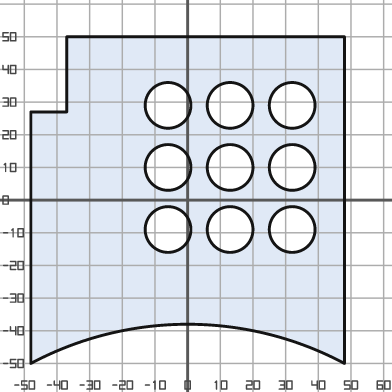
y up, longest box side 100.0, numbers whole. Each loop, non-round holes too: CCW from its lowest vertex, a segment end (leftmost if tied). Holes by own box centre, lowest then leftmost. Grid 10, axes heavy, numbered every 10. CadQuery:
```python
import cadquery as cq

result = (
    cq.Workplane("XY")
    .moveTo(-48.0, -50.0)
    .threePointArc((0.0, -38.0), (48.0, -50.0))
    .lineTo(48.0, 50.0)
    .lineTo(-37.0, 50.0)
    .lineTo(-37.0, 27.0)
    .lineTo(-48.0, 27.0)
    .close()
    .moveTo(-6.0, -9.0)
    .circle(7.0)
    .moveTo(13.0, -9.0)
    .circle(7.0)
    .moveTo(32.0, -9.0)
    .circle(7.0)
    .moveTo(-6.0, 10.0)
    .circle(7.0)
    .moveTo(13.0, 10.0)
    .circle(7.0)
    .moveTo(32.0, 10.0)
    .circle(7.0)
    .moveTo(-6.0, 29.0)
    .circle(7.0)
    .moveTo(13.0, 29.0)
    .circle(7.0)
    .moveTo(32.0, 29.0)
    .circle(7.0)
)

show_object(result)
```